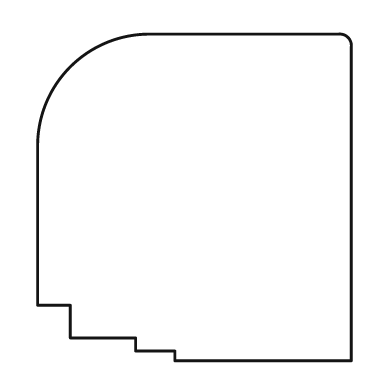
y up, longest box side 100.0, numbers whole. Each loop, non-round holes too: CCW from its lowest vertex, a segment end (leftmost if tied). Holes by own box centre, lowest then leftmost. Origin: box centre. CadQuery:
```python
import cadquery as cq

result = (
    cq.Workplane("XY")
    .moveTo(-6.0, -50.0)
    .lineTo(48.0, -50.0)
    .lineTo(48.0, 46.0)
    .threePointArc((47.0, 49.0), (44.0, 50.0))
    .lineTo(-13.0, 50.0)
    .threePointArc((-38.0, 40.0), (-48.0, 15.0))
    .lineTo(-48.0, -33.0)
    .lineTo(-38.0, -33.0)
    .lineTo(-38.0, -43.0)
    .lineTo(-18.0, -43.0)
    .lineTo(-18.0, -47.0)
    .lineTo(-6.0, -47.0)
    .close()
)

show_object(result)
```